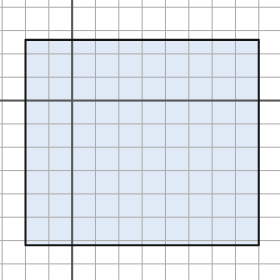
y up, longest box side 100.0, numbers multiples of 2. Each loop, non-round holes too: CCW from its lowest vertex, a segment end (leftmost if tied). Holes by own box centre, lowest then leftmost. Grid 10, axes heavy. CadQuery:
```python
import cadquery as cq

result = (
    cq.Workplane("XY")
    .moveTo(-20.0, -62.0)
    .lineTo(80.0, -62.0)
    .lineTo(80.0, 26.0)
    .lineTo(-20.0, 26.0)
    .close()
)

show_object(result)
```